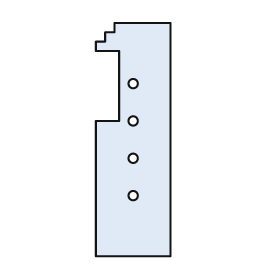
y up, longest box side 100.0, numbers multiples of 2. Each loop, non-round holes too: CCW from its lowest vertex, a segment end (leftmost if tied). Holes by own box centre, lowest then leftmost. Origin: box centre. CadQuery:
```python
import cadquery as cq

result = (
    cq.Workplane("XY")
    .moveTo(-16.0, -50.0)
    .lineTo(16.0, -50.0)
    .lineTo(16.0, 50.0)
    .lineTo(-8.0, 50.0)
    .lineTo(-8.0, 46.0)
    .lineTo(-12.0, 46.0)
    .lineTo(-12.0, 42.0)
    .lineTo(-16.0, 42.0)
    .lineTo(-16.0, 38.0)
    .lineTo(-6.0, 38.0)
    .lineTo(-6.0, 8.0)
    .lineTo(-16.0, 8.0)
    .close()
    .moveTo(0.0, -24.0)
    .circle(2.0)
    .moveTo(0.0, -8.0)
    .circle(2.0)
    .moveTo(0.0, 8.0)
    .circle(2.0)
    .moveTo(0.0, 24.0)
    .circle(2.0)
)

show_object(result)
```